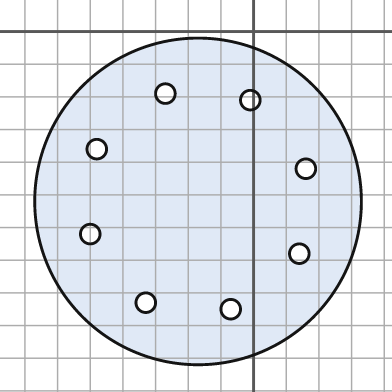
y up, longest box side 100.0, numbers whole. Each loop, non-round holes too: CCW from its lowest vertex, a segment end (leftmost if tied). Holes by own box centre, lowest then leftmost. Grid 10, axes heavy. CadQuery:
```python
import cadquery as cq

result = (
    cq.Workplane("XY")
    .moveTo(-17.0, -52.0)
    .circle(50.0)
    .moveTo(-7.0, -85.0)
    .circle(3.0)
    .moveTo(-33.0, -83.0)
    .circle(3.0)
    .moveTo(14.0, -68.0)
    .circle(3.0)
    .moveTo(-50.0, -62.0)
    .circle(3.0)
    .moveTo(16.0, -42.0)
    .circle(3.0)
    .moveTo(-48.0, -36.0)
    .circle(3.0)
    .moveTo(-1.0, -21.0)
    .circle(3.0)
    .moveTo(-27.0, -19.0)
    .circle(3.0)
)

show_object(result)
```